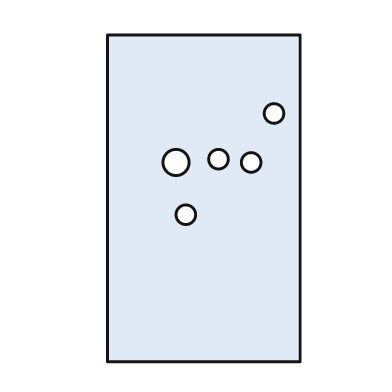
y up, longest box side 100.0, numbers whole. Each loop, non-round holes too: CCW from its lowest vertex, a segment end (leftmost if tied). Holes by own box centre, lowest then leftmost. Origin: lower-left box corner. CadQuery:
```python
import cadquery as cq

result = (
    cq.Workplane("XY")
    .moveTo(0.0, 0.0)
    .lineTo(59.0, 0.0)
    .lineTo(59.0, 100.0)
    .lineTo(0.0, 100.0)
    .close()
    .moveTo(24.0, 45.0)
    .circle(3.0)
    .moveTo(21.0, 61.0)
    .circle(4.0)
    .moveTo(44.0, 61.0)
    .circle(3.0)
    .moveTo(34.0, 62.0)
    .circle(3.0)
    .moveTo(51.0, 76.0)
    .circle(3.0)
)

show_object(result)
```